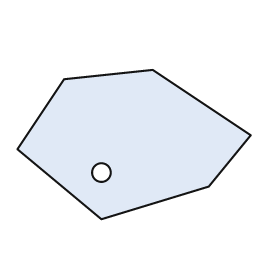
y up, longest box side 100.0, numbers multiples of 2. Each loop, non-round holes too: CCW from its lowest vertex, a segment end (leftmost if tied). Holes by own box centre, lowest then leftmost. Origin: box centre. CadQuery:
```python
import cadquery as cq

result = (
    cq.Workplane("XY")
    .moveTo(-14.0, -32.0)
    .lineTo(32.0, -18.0)
    .lineTo(50.0, 4.0)
    .lineTo(8.0, 32.0)
    .lineTo(-30.0, 28.0)
    .lineTo(-50.0, -2.0)
    .close()
    .moveTo(-14.0, -12.0)
    .circle(4.0)
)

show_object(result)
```